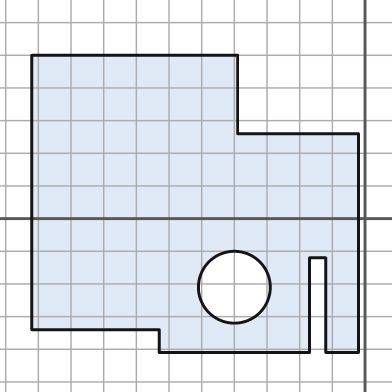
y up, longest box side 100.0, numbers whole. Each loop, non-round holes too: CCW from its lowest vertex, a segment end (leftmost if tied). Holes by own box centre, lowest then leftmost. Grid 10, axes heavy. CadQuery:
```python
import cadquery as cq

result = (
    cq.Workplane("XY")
    .moveTo(-63.0, -41.0)
    .lineTo(-17.0, -41.0)
    .lineTo(-17.0, -12.0)
    .lineTo(-12.0, -12.0)
    .lineTo(-12.0, -41.0)
    .lineTo(-2.0, -41.0)
    .lineTo(-2.0, 26.0)
    .lineTo(-39.0, 26.0)
    .lineTo(-39.0, 50.0)
    .lineTo(-102.0, 50.0)
    .lineTo(-102.0, -34.0)
    .lineTo(-63.0, -34.0)
    .close()
    .moveTo(-40.0, -21.0)
    .circle(11.0)
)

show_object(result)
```